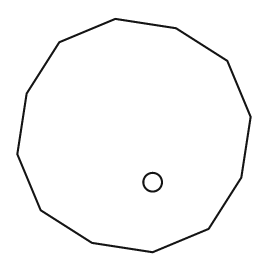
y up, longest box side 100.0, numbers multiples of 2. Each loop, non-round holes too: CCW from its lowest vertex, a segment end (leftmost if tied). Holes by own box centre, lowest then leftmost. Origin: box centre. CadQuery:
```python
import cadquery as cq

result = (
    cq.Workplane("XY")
    .moveTo(8.0, -50.0)
    .lineTo(32.0, -40.0)
    .lineTo(46.0, -18.0)
    .lineTo(50.0, 8.0)
    .lineTo(40.0, 32.0)
    .lineTo(18.0, 46.0)
    .lineTo(-8.0, 50.0)
    .lineTo(-32.0, 40.0)
    .lineTo(-46.0, 18.0)
    .lineTo(-50.0, -8.0)
    .lineTo(-40.0, -32.0)
    .lineTo(-18.0, -46.0)
    .close()
    .moveTo(8.0, -20.0)
    .circle(4.0)
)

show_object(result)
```